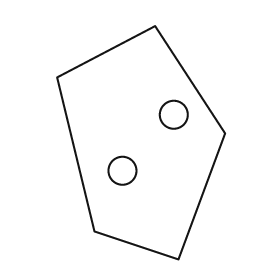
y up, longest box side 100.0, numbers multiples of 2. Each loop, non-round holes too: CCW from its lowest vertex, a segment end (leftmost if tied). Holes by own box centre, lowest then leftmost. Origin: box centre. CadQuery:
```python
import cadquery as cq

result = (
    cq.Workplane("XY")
    .moveTo(16.0, -50.0)
    .lineTo(36.0, 4.0)
    .lineTo(6.0, 50.0)
    .lineTo(-36.0, 28.0)
    .lineTo(-20.0, -38.0)
    .close()
    .moveTo(-8.0, -12.0)
    .circle(6.0)
    .moveTo(14.0, 12.0)
    .circle(6.0)
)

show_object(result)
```